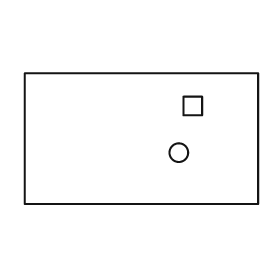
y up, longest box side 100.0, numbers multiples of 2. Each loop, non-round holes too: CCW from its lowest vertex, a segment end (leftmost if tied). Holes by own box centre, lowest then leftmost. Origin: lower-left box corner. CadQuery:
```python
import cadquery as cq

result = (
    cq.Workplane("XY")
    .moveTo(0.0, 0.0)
    .lineTo(100.0, 0.0)
    .lineTo(100.0, 56.0)
    .lineTo(0.0, 56.0)
    .close()
    .moveTo(66.0, 22.0)
    .circle(4.0)
    .moveTo(68.0, 38.0)
    .lineTo(76.0, 38.0)
    .lineTo(76.0, 46.0)
    .lineTo(68.0, 46.0)
    .close()
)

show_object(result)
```